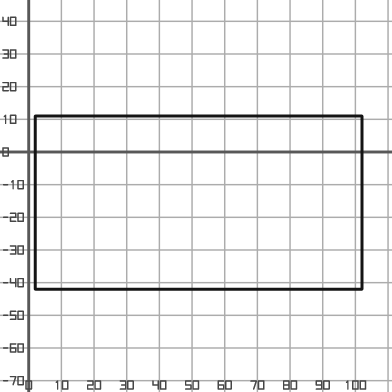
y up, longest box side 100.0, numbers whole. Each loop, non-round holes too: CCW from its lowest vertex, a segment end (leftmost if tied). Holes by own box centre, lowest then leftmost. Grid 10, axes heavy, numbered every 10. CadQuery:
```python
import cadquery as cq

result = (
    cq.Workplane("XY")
    .moveTo(2.0, -42.0)
    .lineTo(102.0, -42.0)
    .lineTo(102.0, 11.0)
    .lineTo(2.0, 11.0)
    .close()
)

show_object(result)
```